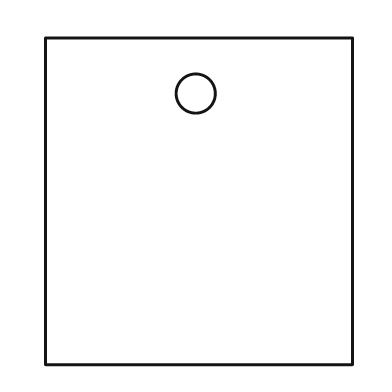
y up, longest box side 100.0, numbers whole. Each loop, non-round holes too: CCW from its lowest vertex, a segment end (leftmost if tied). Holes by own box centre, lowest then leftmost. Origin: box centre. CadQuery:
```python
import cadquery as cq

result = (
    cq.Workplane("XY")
    .moveTo(-47.0, -50.0)
    .lineTo(47.0, -50.0)
    .lineTo(47.0, 50.0)
    .lineTo(-47.0, 50.0)
    .close()
    .moveTo(-1.0, 33.0)
    .circle(6.0)
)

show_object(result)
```